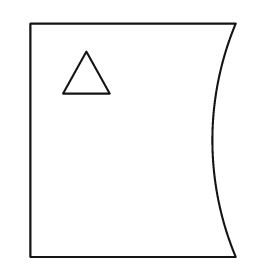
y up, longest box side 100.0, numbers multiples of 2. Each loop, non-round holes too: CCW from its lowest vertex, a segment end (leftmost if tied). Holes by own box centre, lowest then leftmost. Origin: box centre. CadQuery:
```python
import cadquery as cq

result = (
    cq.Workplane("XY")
    .moveTo(-44.0, -50.0)
    .lineTo(44.0, -50.0)
    .threePointArc((34.0, 0.0), (44.0, 50.0))
    .lineTo(-44.0, 50.0)
    .close()
    .moveTo(-30.0, 20.0)
    .lineTo(-10.0, 20.0)
    .lineTo(-20.0, 38.0)
    .close()
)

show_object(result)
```